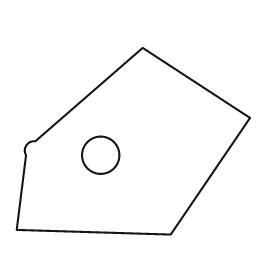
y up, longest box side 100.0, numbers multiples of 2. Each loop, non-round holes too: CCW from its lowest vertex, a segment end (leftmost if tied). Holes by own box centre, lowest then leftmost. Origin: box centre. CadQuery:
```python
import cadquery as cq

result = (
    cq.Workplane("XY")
    .moveTo(16.0, -40.0)
    .lineTo(50.0, 10.0)
    .lineTo(4.0, 40.0)
    .lineTo(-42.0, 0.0)
    .threePointArc((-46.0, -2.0), (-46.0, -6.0))
    .lineTo(-50.0, -38.0)
    .close()
    .moveTo(-14.0, -6.0)
    .circle(8.0)
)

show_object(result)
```